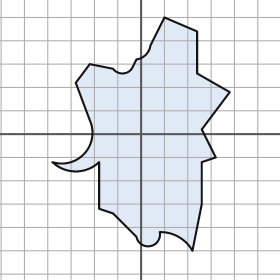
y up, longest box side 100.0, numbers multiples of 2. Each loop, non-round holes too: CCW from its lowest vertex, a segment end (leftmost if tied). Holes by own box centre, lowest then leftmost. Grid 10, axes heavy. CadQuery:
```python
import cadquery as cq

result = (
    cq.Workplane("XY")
    .moveTo(22.0, -50.0)
    .lineTo(26.0, -30.0)
    .lineTo(26.0, -12.0)
    .lineTo(32.0, -10.0)
    .lineTo(26.0, 2.0)
    .lineTo(38.0, 18.0)
    .lineTo(24.0, 26.0)
    .lineTo(24.0, 44.0)
    .lineTo(10.0, 50.0)
    .lineTo(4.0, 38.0)
    .threePointArc((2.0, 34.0), (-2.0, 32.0))
    .lineTo(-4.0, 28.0)
    .threePointArc((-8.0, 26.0), (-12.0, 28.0))
    .lineTo(-22.0, 30.0)
    .lineTo(-28.0, 22.0)
    .lineTo(-22.0, 6.0)
    .threePointArc((-24.0, -8.0), (-38.0, -12.0))
    .threePointArc((-28.0, -16.0), (-18.0, -12.0))
    .lineTo(-18.0, -32.0)
    .lineTo(-12.0, -34.0)
    .lineTo(-2.0, -44.0)
    .threePointArc((4.0, -48.0), (8.0, -42.0))
    .threePointArc((16.0, -44.0), (22.0, -50.0))
    .close()
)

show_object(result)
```